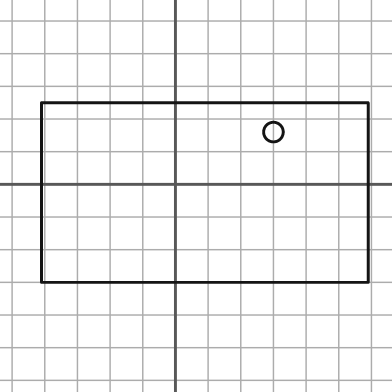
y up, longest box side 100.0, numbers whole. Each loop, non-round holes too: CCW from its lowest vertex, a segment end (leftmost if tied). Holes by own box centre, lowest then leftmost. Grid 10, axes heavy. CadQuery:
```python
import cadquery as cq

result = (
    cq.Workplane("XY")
    .moveTo(-41.0, -30.0)
    .lineTo(59.0, -30.0)
    .lineTo(59.0, 25.0)
    .lineTo(-41.0, 25.0)
    .close()
    .moveTo(30.0, 16.0)
    .circle(3.0)
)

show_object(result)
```